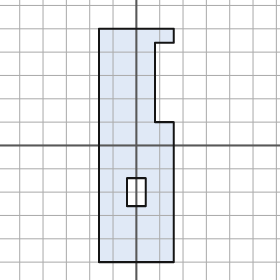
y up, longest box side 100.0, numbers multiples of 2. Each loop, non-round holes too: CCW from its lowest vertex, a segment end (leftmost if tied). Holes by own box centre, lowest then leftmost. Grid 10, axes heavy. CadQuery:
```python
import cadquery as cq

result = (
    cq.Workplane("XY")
    .moveTo(-16.0, -50.0)
    .lineTo(16.0, -50.0)
    .lineTo(16.0, 10.0)
    .lineTo(8.0, 10.0)
    .lineTo(8.0, 44.0)
    .lineTo(16.0, 44.0)
    .lineTo(16.0, 50.0)
    .lineTo(-16.0, 50.0)
    .close()
    .moveTo(-4.0, -26.0)
    .lineTo(4.0, -26.0)
    .lineTo(4.0, -14.0)
    .lineTo(-4.0, -14.0)
    .close()
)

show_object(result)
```